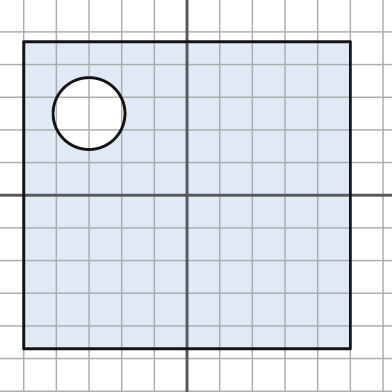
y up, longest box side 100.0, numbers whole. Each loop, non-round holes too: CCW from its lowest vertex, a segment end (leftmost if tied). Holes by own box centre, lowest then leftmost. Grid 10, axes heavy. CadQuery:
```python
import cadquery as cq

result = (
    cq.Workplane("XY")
    .moveTo(-50.0, -47.0)
    .lineTo(50.0, -47.0)
    .lineTo(50.0, 47.0)
    .lineTo(-50.0, 47.0)
    .close()
    .moveTo(-30.0, 25.0)
    .circle(11.0)
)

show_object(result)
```